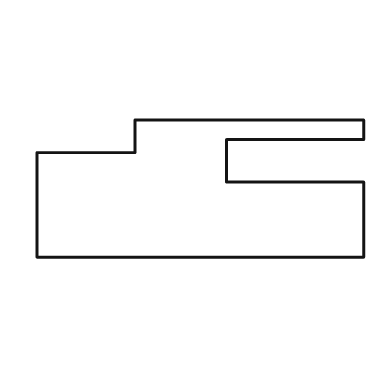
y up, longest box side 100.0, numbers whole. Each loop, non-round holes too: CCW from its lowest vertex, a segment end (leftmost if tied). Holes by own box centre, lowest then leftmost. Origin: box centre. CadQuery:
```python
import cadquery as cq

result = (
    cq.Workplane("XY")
    .moveTo(-50.0, -21.0)
    .lineTo(50.0, -21.0)
    .lineTo(50.0, 2.0)
    .lineTo(8.0, 2.0)
    .lineTo(8.0, 15.0)
    .lineTo(50.0, 15.0)
    .lineTo(50.0, 21.0)
    .lineTo(-20.0, 21.0)
    .lineTo(-20.0, 11.0)
    .lineTo(-50.0, 11.0)
    .close()
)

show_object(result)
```